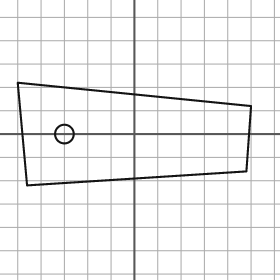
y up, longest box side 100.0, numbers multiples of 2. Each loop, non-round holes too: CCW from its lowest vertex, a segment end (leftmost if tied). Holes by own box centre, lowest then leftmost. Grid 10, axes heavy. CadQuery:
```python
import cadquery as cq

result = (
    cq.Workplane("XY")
    .moveTo(-46.0, -22.0)
    .lineTo(48.0, -16.0)
    .lineTo(50.0, 12.0)
    .lineTo(-50.0, 22.0)
    .close()
    .moveTo(-30.0, 0.0)
    .circle(4.0)
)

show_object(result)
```